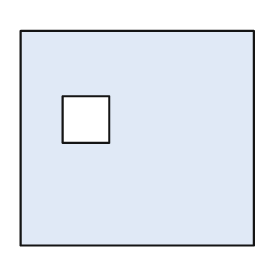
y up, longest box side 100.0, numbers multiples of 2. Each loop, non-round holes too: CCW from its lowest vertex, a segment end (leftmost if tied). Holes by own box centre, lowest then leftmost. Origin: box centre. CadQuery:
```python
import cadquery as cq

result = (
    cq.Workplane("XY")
    .moveTo(-50.0, -46.0)
    .lineTo(50.0, -46.0)
    .lineTo(50.0, 46.0)
    .lineTo(-50.0, 46.0)
    .close()
    .moveTo(-32.0, -2.0)
    .lineTo(-12.0, -2.0)
    .lineTo(-12.0, 18.0)
    .lineTo(-32.0, 18.0)
    .close()
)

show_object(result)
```